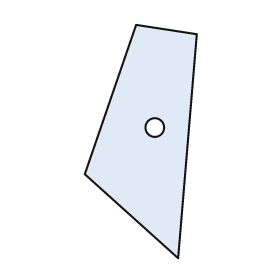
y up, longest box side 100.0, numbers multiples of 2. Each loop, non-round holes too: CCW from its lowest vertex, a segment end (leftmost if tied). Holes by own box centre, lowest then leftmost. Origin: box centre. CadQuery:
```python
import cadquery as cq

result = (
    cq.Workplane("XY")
    .moveTo(16.0, -50.0)
    .lineTo(24.0, 46.0)
    .lineTo(-2.0, 50.0)
    .lineTo(-24.0, -14.0)
    .close()
    .moveTo(6.0, 6.0)
    .circle(4.0)
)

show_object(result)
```